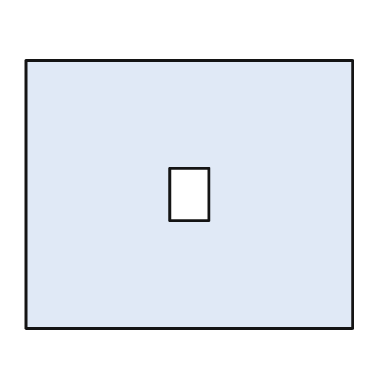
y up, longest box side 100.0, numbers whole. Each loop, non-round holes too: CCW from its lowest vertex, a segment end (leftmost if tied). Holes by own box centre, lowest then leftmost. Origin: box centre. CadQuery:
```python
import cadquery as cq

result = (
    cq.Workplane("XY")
    .moveTo(-50.0, -41.0)
    .lineTo(50.0, -41.0)
    .lineTo(50.0, 41.0)
    .lineTo(-50.0, 41.0)
    .close()
    .moveTo(-6.0, -8.0)
    .lineTo(6.0, -8.0)
    .lineTo(6.0, 8.0)
    .lineTo(-6.0, 8.0)
    .close()
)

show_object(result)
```